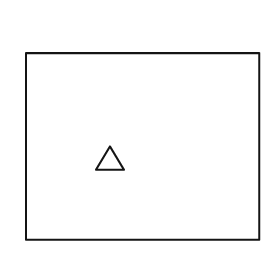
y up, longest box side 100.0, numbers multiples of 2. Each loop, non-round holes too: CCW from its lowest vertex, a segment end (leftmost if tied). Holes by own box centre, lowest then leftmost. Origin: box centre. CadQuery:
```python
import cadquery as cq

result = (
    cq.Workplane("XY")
    .moveTo(-50.0, -40.0)
    .lineTo(50.0, -40.0)
    .lineTo(50.0, 40.0)
    .lineTo(-50.0, 40.0)
    .close()
    .moveTo(-20.0, -10.0)
    .lineTo(-8.0, -10.0)
    .lineTo(-14.0, 0.0)
    .close()
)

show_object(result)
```